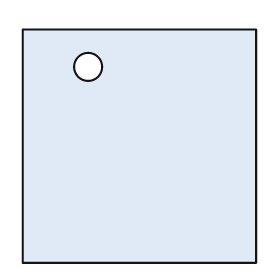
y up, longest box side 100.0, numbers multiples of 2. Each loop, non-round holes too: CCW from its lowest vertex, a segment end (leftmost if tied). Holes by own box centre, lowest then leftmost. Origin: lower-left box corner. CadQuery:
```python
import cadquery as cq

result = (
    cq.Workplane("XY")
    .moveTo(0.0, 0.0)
    .lineTo(100.0, 0.0)
    .lineTo(100.0, 100.0)
    .lineTo(0.0, 100.0)
    .close()
    .moveTo(28.0, 84.0)
    .circle(6.0)
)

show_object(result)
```